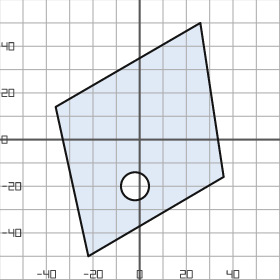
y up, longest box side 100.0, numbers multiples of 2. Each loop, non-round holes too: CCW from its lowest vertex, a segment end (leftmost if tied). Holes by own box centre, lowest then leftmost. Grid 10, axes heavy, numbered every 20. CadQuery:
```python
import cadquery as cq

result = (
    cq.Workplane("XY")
    .moveTo(-22.0, -50.0)
    .lineTo(36.0, -16.0)
    .lineTo(26.0, 50.0)
    .lineTo(-36.0, 14.0)
    .close()
    .moveTo(-2.0, -20.0)
    .circle(6.0)
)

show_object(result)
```